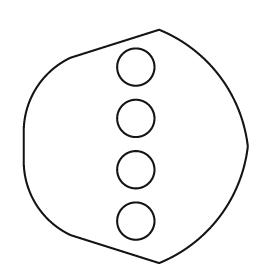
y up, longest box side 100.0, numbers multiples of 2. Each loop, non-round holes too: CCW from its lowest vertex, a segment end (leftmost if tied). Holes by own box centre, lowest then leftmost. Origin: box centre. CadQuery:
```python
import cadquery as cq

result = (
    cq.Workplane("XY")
    .moveTo(10.0, -50.0)
    .threePointArc((36.0, -30.0), (48.0, 0.0))
    .threePointArc((36.0, 30.0), (10.0, 50.0))
    .lineTo(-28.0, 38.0)
    .threePointArc((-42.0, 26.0), (-48.0, 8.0))
    .lineTo(-48.0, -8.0)
    .threePointArc((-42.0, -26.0), (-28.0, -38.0))
    .close()
    .moveTo(0.0, -32.0)
    .circle(8.0)
    .moveTo(0.0, -10.0)
    .circle(8.0)
    .moveTo(0.0, 12.0)
    .circle(8.0)
    .moveTo(0.0, 34.0)
    .circle(8.0)
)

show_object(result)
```